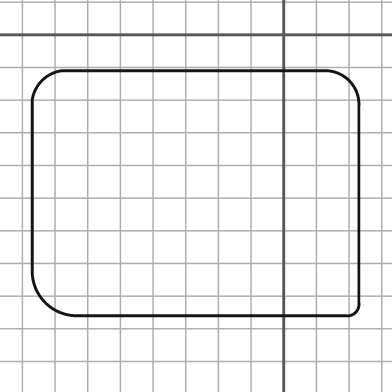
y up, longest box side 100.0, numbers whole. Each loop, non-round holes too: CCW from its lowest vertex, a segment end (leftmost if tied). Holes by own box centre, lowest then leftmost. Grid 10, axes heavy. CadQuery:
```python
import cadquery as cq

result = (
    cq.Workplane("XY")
    .moveTo(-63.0, -86.0)
    .lineTo(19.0, -86.0)
    .threePointArc((22.0, -85.0), (23.0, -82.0))
    .lineTo(23.0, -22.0)
    .threePointArc((20.0, -14.0), (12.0, -11.0))
    .lineTo(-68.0, -11.0)
    .threePointArc((-74.0, -14.0), (-77.0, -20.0))
    .lineTo(-77.0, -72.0)
    .threePointArc((-73.0, -82.0), (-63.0, -86.0))
    .close()
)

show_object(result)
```